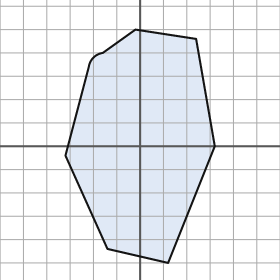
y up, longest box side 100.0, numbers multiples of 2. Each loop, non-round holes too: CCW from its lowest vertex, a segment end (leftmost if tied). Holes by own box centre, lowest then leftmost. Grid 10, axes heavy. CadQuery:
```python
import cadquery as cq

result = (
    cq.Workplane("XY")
    .moveTo(12.0, -50.0)
    .lineTo(32.0, 0.0)
    .lineTo(24.0, 46.0)
    .lineTo(-2.0, 50.0)
    .lineTo(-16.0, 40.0)
    .threePointArc((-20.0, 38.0), (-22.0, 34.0))
    .lineTo(-32.0, -4.0)
    .lineTo(-14.0, -44.0)
    .close()
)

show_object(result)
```